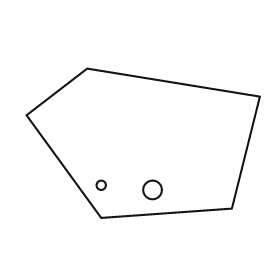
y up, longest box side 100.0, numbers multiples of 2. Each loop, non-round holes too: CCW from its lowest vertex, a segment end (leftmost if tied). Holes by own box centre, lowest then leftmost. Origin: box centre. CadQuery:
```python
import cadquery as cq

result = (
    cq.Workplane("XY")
    .moveTo(-18.0, -32.0)
    .lineTo(38.0, -28.0)
    .lineTo(50.0, 20.0)
    .lineTo(-24.0, 32.0)
    .lineTo(-50.0, 12.0)
    .close()
    .moveTo(4.0, -20.0)
    .circle(4.0)
    .moveTo(-18.0, -18.0)
    .circle(2.0)
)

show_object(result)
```